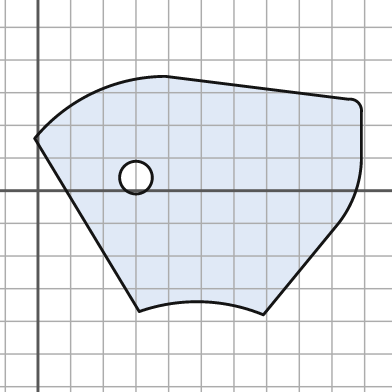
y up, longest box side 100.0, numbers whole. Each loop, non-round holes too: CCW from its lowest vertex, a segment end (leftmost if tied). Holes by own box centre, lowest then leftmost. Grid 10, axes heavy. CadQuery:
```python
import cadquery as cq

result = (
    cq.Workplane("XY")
    .moveTo(69.0, -38.0)
    .lineTo(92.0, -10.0)
    .threePointArc((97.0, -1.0), (99.0, 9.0))
    .lineTo(99.0, 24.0)
    .threePointArc((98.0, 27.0), (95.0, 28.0))
    .lineTo(39.0, 35.0)
    .threePointArc((17.0, 30.0), (-1.0, 16.0))
    .lineTo(31.0, -37.0)
    .threePointArc((50.0, -34.0), (69.0, -38.0))
    .close()
    .moveTo(30.0, 4.0)
    .circle(5.0)
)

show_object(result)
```